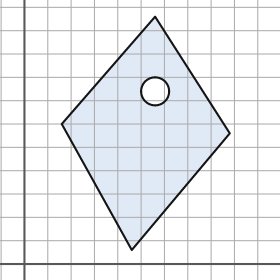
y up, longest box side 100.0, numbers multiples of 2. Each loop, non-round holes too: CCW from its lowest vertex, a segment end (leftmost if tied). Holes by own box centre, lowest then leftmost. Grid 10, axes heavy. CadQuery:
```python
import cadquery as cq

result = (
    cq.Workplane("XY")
    .moveTo(46.0, 6.0)
    .lineTo(88.0, 56.0)
    .lineTo(56.0, 106.0)
    .lineTo(16.0, 60.0)
    .close()
    .moveTo(56.0, 74.0)
    .circle(6.0)
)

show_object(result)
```